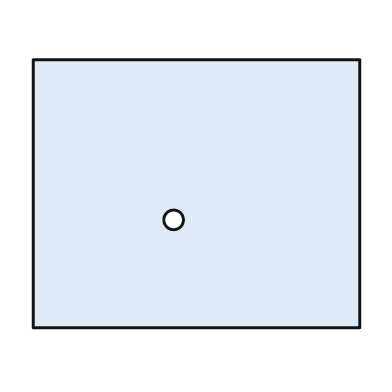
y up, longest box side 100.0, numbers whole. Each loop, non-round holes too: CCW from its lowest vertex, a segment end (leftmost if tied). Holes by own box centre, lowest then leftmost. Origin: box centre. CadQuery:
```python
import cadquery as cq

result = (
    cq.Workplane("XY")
    .moveTo(-50.0, -41.0)
    .lineTo(50.0, -41.0)
    .lineTo(50.0, 41.0)
    .lineTo(-50.0, 41.0)
    .close()
    .moveTo(-7.0, -8.0)
    .circle(3.0)
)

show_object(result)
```